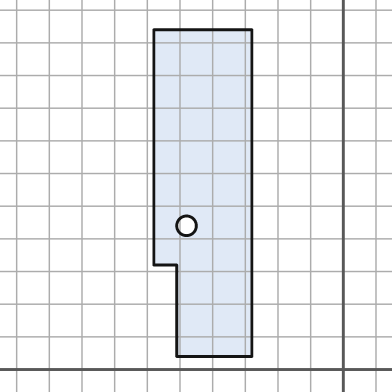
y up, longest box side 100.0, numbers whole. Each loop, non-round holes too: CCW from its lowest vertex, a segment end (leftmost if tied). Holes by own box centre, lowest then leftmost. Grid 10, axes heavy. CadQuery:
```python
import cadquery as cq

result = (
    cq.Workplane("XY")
    .moveTo(-51.0, 4.0)
    .lineTo(-28.0, 4.0)
    .lineTo(-28.0, 104.0)
    .lineTo(-58.0, 104.0)
    .lineTo(-58.0, 32.0)
    .lineTo(-51.0, 32.0)
    .close()
    .moveTo(-48.0, 44.0)
    .circle(3.0)
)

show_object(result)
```